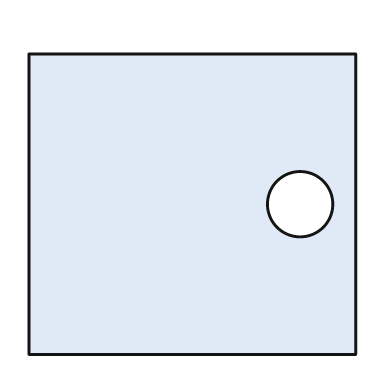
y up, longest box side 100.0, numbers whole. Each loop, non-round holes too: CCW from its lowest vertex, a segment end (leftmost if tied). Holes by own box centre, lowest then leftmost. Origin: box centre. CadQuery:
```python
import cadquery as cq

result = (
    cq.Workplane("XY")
    .moveTo(-50.0, -46.0)
    .lineTo(50.0, -46.0)
    .lineTo(50.0, 46.0)
    .lineTo(-50.0, 46.0)
    .close()
    .moveTo(33.0, 0.0)
    .circle(10.0)
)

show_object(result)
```